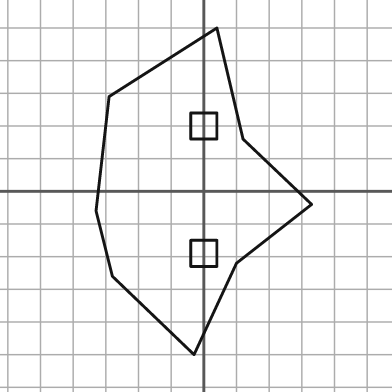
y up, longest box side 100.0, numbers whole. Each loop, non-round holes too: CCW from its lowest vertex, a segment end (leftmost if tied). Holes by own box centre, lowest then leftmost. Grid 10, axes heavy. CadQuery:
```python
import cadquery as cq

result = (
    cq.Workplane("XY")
    .moveTo(-3.0, -50.0)
    .lineTo(10.0, -22.0)
    .lineTo(33.0, -4.0)
    .lineTo(12.0, 16.0)
    .lineTo(4.0, 50.0)
    .lineTo(-29.0, 29.0)
    .lineTo(-33.0, -6.0)
    .lineTo(-28.0, -26.0)
    .close()
    .moveTo(-4.0, -23.0)
    .lineTo(4.0, -23.0)
    .lineTo(4.0, -15.0)
    .lineTo(-4.0, -15.0)
    .close()
    .moveTo(-4.0, 16.0)
    .lineTo(4.0, 16.0)
    .lineTo(4.0, 24.0)
    .lineTo(-4.0, 24.0)
    .close()
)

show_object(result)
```